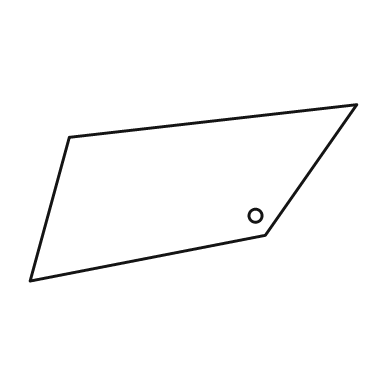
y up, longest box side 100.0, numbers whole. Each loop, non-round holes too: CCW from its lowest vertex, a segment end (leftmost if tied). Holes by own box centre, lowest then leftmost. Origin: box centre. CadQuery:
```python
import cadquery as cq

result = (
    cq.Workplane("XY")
    .moveTo(-50.0, -27.0)
    .lineTo(22.0, -13.0)
    .lineTo(50.0, 27.0)
    .lineTo(-38.0, 17.0)
    .close()
    .moveTo(19.0, -7.0)
    .circle(2.0)
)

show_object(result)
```